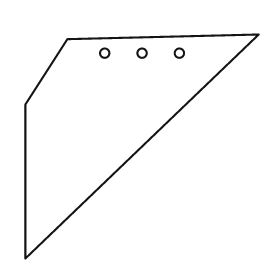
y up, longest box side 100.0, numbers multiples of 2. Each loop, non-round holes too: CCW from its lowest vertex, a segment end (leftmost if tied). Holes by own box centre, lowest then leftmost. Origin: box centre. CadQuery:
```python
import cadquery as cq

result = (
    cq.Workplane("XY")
    .moveTo(-50.0, -48.0)
    .lineTo(50.0, 48.0)
    .lineTo(-32.0, 46.0)
    .lineTo(-50.0, 18.0)
    .close()
    .moveTo(-16.0, 40.0)
    .circle(2.0)
    .moveTo(0.0, 40.0)
    .circle(2.0)
    .moveTo(16.0, 40.0)
    .circle(2.0)
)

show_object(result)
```